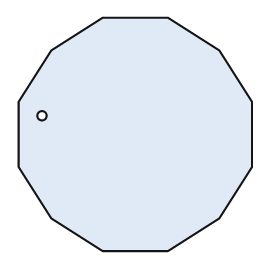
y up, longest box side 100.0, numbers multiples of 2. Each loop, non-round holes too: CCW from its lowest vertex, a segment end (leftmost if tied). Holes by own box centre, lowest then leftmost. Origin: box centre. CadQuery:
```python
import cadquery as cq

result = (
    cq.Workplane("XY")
    .moveTo(-14.0, -50.0)
    .lineTo(14.0, -50.0)
    .lineTo(36.0, -36.0)
    .lineTo(50.0, -14.0)
    .lineTo(50.0, 14.0)
    .lineTo(36.0, 36.0)
    .lineTo(14.0, 50.0)
    .lineTo(-14.0, 50.0)
    .lineTo(-36.0, 36.0)
    .lineTo(-50.0, 14.0)
    .lineTo(-50.0, -14.0)
    .lineTo(-36.0, -36.0)
    .close()
    .moveTo(-40.0, 8.0)
    .circle(2.0)
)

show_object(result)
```